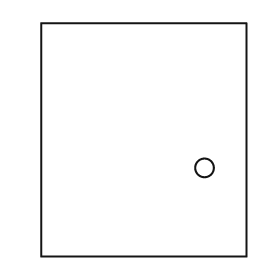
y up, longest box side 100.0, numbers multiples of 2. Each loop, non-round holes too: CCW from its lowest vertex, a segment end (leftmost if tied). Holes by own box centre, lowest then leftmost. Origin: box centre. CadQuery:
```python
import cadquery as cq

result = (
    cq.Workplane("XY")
    .moveTo(-44.0, -50.0)
    .lineTo(44.0, -50.0)
    .lineTo(44.0, 50.0)
    .lineTo(-44.0, 50.0)
    .close()
    .moveTo(26.0, -12.0)
    .circle(4.0)
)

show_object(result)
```